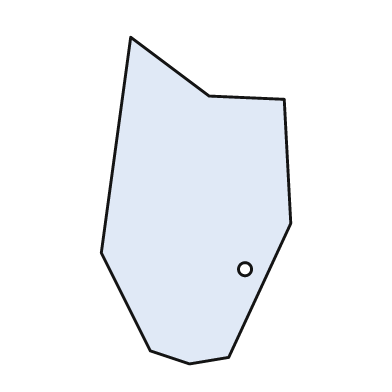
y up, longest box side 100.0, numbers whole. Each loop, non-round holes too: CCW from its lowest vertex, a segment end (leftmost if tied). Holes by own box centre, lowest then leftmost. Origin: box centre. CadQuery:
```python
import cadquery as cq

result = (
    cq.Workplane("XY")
    .moveTo(-2.0, -50.0)
    .lineTo(10.0, -48.0)
    .lineTo(29.0, -7.0)
    .lineTo(27.0, 31.0)
    .lineTo(4.0, 32.0)
    .lineTo(-20.0, 50.0)
    .lineTo(-29.0, -16.0)
    .lineTo(-14.0, -46.0)
    .close()
    .moveTo(15.0, -21.0)
    .circle(2.0)
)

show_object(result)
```